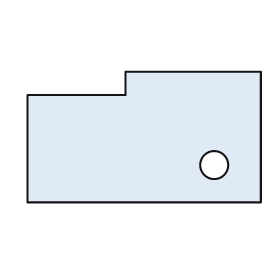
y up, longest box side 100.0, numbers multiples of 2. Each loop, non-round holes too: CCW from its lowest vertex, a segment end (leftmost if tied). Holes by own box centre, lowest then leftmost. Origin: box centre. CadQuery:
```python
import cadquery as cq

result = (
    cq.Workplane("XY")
    .moveTo(-50.0, -28.0)
    .lineTo(50.0, -28.0)
    .lineTo(50.0, 28.0)
    .lineTo(-8.0, 28.0)
    .lineTo(-8.0, 18.0)
    .lineTo(-50.0, 18.0)
    .close()
    .moveTo(30.0, -12.0)
    .circle(6.0)
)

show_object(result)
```